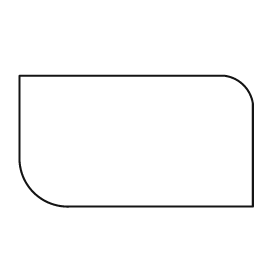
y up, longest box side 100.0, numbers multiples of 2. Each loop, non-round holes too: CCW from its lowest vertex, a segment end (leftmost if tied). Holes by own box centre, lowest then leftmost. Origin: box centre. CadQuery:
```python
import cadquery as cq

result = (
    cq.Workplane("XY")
    .moveTo(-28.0, -28.0)
    .lineTo(50.0, -28.0)
    .lineTo(50.0, 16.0)
    .threePointArc((46.0, 24.0), (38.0, 28.0))
    .lineTo(-50.0, 28.0)
    .lineTo(-50.0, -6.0)
    .threePointArc((-44.0, -22.0), (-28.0, -28.0))
    .close()
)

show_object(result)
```